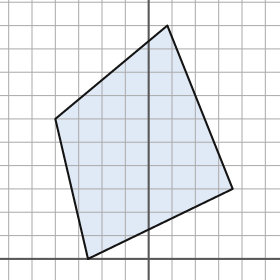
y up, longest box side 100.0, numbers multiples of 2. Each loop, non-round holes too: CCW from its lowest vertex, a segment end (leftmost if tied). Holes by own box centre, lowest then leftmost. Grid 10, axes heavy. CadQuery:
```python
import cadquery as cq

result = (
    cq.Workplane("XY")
    .moveTo(-26.0, 0.0)
    .lineTo(36.0, 30.0)
    .lineTo(8.0, 100.0)
    .lineTo(-40.0, 60.0)
    .close()
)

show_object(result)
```